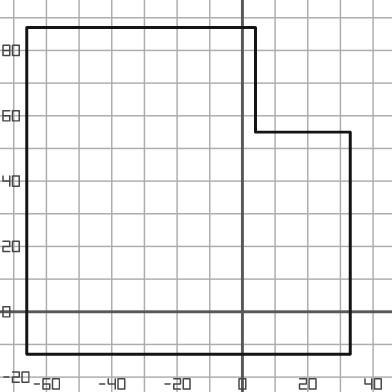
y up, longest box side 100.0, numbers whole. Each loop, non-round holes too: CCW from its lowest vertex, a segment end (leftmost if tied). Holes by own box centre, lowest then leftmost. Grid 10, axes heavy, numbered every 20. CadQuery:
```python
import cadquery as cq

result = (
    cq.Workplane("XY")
    .moveTo(-66.0, -13.0)
    .lineTo(33.0, -13.0)
    .lineTo(33.0, 55.0)
    .lineTo(4.0, 55.0)
    .lineTo(4.0, 87.0)
    .lineTo(-66.0, 87.0)
    .close()
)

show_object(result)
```